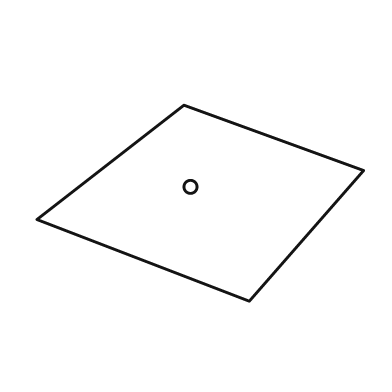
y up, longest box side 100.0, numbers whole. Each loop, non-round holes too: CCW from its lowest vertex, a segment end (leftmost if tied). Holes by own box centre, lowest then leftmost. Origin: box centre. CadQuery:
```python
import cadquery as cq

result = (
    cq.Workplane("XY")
    .moveTo(15.0, -30.0)
    .lineTo(50.0, 10.0)
    .lineTo(-5.0, 30.0)
    .lineTo(-50.0, -5.0)
    .close()
    .moveTo(-3.0, 5.0)
    .circle(2.0)
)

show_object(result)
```